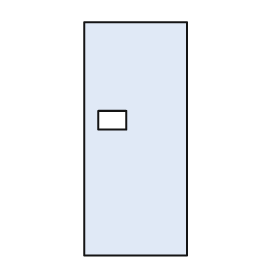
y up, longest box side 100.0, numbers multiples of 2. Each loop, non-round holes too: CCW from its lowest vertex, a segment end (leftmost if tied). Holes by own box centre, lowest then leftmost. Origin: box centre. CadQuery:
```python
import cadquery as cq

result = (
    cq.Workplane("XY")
    .moveTo(-22.0, -50.0)
    .lineTo(22.0, -50.0)
    .lineTo(22.0, 50.0)
    .lineTo(-22.0, 50.0)
    .close()
    .moveTo(-16.0, 4.0)
    .lineTo(-4.0, 4.0)
    .lineTo(-4.0, 12.0)
    .lineTo(-16.0, 12.0)
    .close()
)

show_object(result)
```